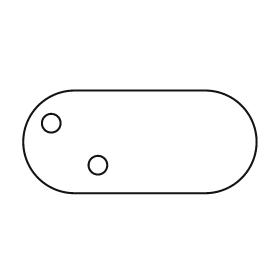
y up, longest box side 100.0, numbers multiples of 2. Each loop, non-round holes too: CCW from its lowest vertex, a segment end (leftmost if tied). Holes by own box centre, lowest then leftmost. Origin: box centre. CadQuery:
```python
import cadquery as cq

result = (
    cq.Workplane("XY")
    .moveTo(-28.0, -22.0)
    .lineTo(28.0, -22.0)
    .threePointArc((50.0, 0.0), (28.0, 22.0))
    .lineTo(-28.0, 22.0)
    .threePointArc((-50.0, 0.0), (-28.0, -22.0))
    .close()
    .moveTo(-18.0, -10.0)
    .circle(4.0)
    .moveTo(-38.0, 8.0)
    .circle(4.0)
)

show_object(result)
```